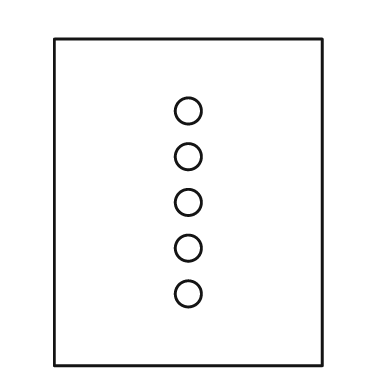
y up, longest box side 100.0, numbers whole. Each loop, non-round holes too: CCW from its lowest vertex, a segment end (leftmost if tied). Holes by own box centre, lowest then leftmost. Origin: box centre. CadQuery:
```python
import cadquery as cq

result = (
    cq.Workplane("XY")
    .moveTo(-41.0, -50.0)
    .lineTo(41.0, -50.0)
    .lineTo(41.0, 50.0)
    .lineTo(-41.0, 50.0)
    .close()
    .moveTo(0.0, -28.0)
    .circle(4.0)
    .moveTo(0.0, -14.0)
    .circle(4.0)
    .moveTo(0.0, 0.0)
    .circle(4.0)
    .moveTo(0.0, 14.0)
    .circle(4.0)
    .moveTo(0.0, 28.0)
    .circle(4.0)
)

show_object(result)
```